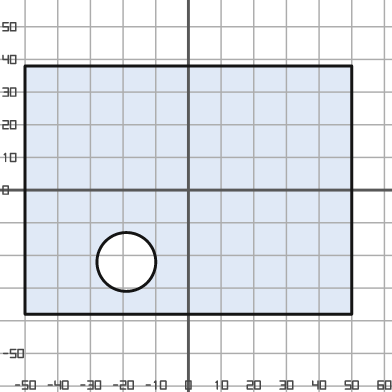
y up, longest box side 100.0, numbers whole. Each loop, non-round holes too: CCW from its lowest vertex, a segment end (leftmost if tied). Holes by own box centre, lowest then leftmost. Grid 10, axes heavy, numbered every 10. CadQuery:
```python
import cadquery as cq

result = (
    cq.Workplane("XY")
    .moveTo(-50.0, -38.0)
    .lineTo(50.0, -38.0)
    .lineTo(50.0, 38.0)
    .lineTo(-50.0, 38.0)
    .close()
    .moveTo(-19.0, -22.0)
    .circle(9.0)
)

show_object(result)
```